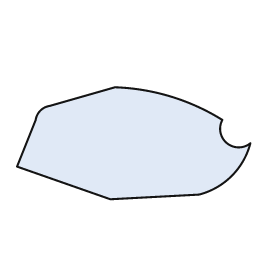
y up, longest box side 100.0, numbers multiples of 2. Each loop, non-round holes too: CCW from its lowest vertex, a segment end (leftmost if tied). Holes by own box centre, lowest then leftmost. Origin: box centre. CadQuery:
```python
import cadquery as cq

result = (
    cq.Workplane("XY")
    .moveTo(-10.0, -24.0)
    .lineTo(28.0, -22.0)
    .threePointArc((42.0, -14.0), (50.0, 0.0))
    .threePointArc((40.0, 0.0), (38.0, 10.0))
    .threePointArc((16.0, 20.0), (-8.0, 24.0))
    .lineTo(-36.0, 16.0)
    .threePointArc((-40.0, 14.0), (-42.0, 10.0))
    .lineTo(-50.0, -10.0)
    .close()
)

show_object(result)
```